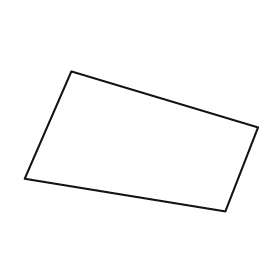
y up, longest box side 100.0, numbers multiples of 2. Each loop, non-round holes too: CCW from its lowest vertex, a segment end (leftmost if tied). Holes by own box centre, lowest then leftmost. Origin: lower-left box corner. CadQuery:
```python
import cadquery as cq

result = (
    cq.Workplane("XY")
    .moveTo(86.0, 0.0)
    .lineTo(100.0, 36.0)
    .lineTo(20.0, 60.0)
    .lineTo(0.0, 14.0)
    .close()
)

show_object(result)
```